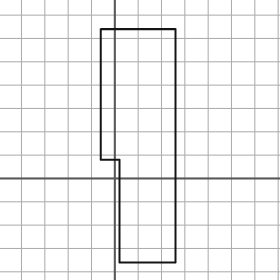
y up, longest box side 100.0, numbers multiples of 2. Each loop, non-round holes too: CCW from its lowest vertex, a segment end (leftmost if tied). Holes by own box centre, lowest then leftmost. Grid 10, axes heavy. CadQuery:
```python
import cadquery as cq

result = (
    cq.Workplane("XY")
    .moveTo(2.0, -36.0)
    .lineTo(26.0, -36.0)
    .lineTo(26.0, 64.0)
    .lineTo(-6.0, 64.0)
    .lineTo(-6.0, 8.0)
    .lineTo(2.0, 8.0)
    .close()
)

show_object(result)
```